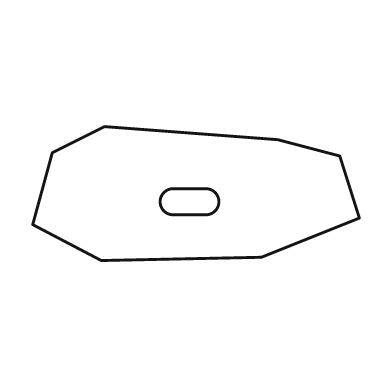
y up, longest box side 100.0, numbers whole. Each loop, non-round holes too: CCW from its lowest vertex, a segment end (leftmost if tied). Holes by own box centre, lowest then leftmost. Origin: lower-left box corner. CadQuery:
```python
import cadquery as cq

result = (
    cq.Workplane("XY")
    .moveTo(21.0, 0.0)
    .lineTo(70.0, 1.0)
    .lineTo(100.0, 13.0)
    .lineTo(94.0, 32.0)
    .lineTo(75.0, 37.0)
    .lineTo(22.0, 41.0)
    .lineTo(6.0, 33.0)
    .lineTo(0.0, 11.0)
    .close()
    .moveTo(43.0, 14.0)
    .lineTo(53.0, 14.0)
    .threePointArc((57.0, 18.0), (53.0, 22.0))
    .lineTo(43.0, 22.0)
    .threePointArc((39.0, 18.0), (43.0, 14.0))
    .close()
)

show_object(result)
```